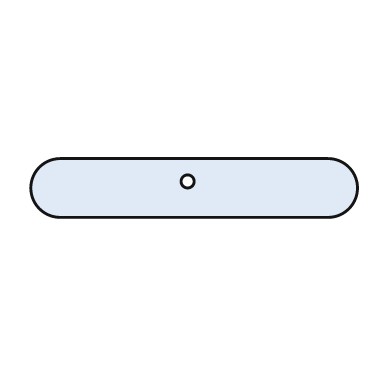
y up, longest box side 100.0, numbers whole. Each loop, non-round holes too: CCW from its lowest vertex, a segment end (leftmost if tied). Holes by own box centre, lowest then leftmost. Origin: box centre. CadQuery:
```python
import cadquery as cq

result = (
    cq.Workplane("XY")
    .moveTo(-41.0, -9.0)
    .lineTo(41.0, -9.0)
    .threePointArc((50.0, 0.0), (41.0, 9.0))
    .lineTo(-41.0, 9.0)
    .threePointArc((-50.0, 0.0), (-41.0, -9.0))
    .close()
    .moveTo(-2.0, 2.0)
    .circle(2.0)
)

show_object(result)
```